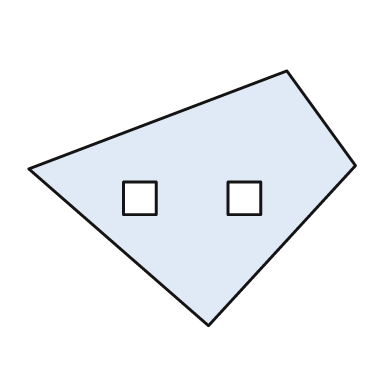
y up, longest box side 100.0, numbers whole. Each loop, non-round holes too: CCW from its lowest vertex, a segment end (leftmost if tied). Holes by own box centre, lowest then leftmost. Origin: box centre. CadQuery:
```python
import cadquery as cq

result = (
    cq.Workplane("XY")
    .moveTo(5.0, -39.0)
    .lineTo(50.0, 10.0)
    .lineTo(29.0, 39.0)
    .lineTo(-50.0, 9.0)
    .close()
    .moveTo(-21.0, -5.0)
    .lineTo(-11.0, -5.0)
    .lineTo(-11.0, 5.0)
    .lineTo(-21.0, 5.0)
    .close()
    .moveTo(11.0, -5.0)
    .lineTo(21.0, -5.0)
    .lineTo(21.0, 5.0)
    .lineTo(11.0, 5.0)
    .close()
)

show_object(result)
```